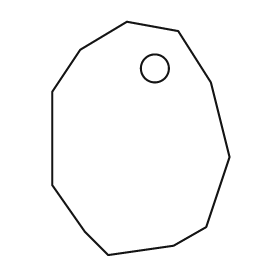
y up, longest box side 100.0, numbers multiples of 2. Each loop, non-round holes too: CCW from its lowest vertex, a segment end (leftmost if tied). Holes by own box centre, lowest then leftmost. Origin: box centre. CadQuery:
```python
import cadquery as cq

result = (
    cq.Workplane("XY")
    .moveTo(-14.0, -50.0)
    .lineTo(14.0, -46.0)
    .lineTo(28.0, -38.0)
    .lineTo(38.0, -8.0)
    .lineTo(30.0, 24.0)
    .lineTo(16.0, 46.0)
    .lineTo(-6.0, 50.0)
    .lineTo(-26.0, 38.0)
    .lineTo(-38.0, 20.0)
    .lineTo(-38.0, -20.0)
    .lineTo(-24.0, -40.0)
    .close()
    .moveTo(6.0, 30.0)
    .circle(6.0)
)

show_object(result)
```